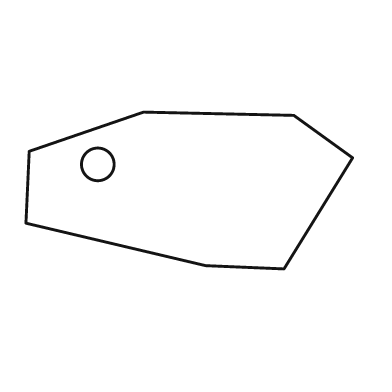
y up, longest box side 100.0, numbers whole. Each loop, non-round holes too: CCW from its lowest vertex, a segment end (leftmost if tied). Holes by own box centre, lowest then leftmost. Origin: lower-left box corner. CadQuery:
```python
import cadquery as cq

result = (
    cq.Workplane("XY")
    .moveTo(79.0, 0.0)
    .lineTo(100.0, 34.0)
    .lineTo(82.0, 47.0)
    .lineTo(36.0, 48.0)
    .lineTo(1.0, 36.0)
    .lineTo(0.0, 14.0)
    .lineTo(55.0, 1.0)
    .close()
    .moveTo(22.0, 32.0)
    .circle(5.0)
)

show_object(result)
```